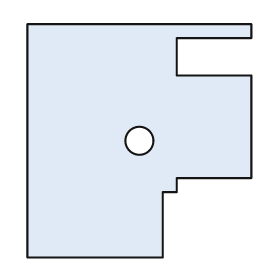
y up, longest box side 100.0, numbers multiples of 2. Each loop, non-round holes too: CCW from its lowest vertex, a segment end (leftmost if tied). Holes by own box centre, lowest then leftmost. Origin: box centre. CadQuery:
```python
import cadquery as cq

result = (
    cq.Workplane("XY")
    .moveTo(-48.0, -50.0)
    .lineTo(10.0, -50.0)
    .lineTo(10.0, -22.0)
    .lineTo(16.0, -22.0)
    .lineTo(16.0, -16.0)
    .lineTo(48.0, -16.0)
    .lineTo(48.0, 28.0)
    .lineTo(16.0, 28.0)
    .lineTo(16.0, 44.0)
    .lineTo(48.0, 44.0)
    .lineTo(48.0, 50.0)
    .lineTo(-48.0, 50.0)
    .close()
    .moveTo(0.0, 0.0)
    .circle(6.0)
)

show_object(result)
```